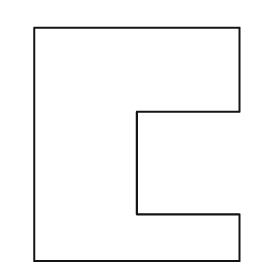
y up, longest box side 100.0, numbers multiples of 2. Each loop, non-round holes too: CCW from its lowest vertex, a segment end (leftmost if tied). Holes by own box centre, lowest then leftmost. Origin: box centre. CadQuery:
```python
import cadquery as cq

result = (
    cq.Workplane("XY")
    .moveTo(-44.0, -50.0)
    .lineTo(44.0, -50.0)
    .lineTo(44.0, -30.0)
    .lineTo(0.0, -30.0)
    .lineTo(0.0, 14.0)
    .lineTo(44.0, 14.0)
    .lineTo(44.0, 50.0)
    .lineTo(-44.0, 50.0)
    .close()
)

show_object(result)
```